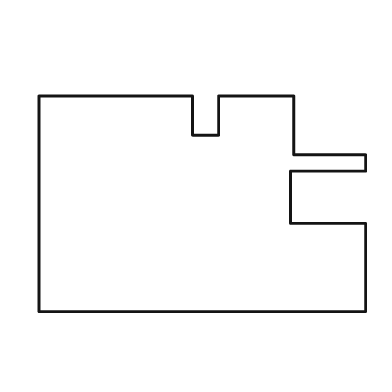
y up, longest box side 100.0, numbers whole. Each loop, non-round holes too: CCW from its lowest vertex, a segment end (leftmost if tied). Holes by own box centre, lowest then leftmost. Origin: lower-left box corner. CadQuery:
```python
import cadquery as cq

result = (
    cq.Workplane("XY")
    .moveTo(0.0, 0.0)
    .lineTo(100.0, 0.0)
    .lineTo(100.0, 27.0)
    .lineTo(77.0, 27.0)
    .lineTo(77.0, 43.0)
    .lineTo(100.0, 43.0)
    .lineTo(100.0, 48.0)
    .lineTo(78.0, 48.0)
    .lineTo(78.0, 66.0)
    .lineTo(55.0, 66.0)
    .lineTo(55.0, 54.0)
    .lineTo(47.0, 54.0)
    .lineTo(47.0, 66.0)
    .lineTo(0.0, 66.0)
    .close()
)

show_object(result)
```